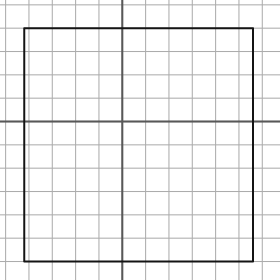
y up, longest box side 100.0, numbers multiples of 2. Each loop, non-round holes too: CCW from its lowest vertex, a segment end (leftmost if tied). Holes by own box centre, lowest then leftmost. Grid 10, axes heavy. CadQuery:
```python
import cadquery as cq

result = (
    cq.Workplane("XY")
    .moveTo(-42.0, -60.0)
    .lineTo(56.0, -60.0)
    .lineTo(56.0, 40.0)
    .lineTo(-42.0, 40.0)
    .close()
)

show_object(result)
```